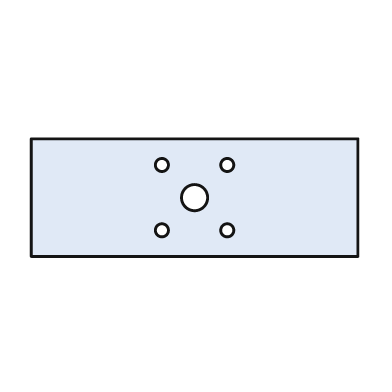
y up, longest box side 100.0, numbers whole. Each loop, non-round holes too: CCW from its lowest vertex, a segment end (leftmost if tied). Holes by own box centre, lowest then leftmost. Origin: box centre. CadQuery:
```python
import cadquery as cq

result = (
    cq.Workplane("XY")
    .moveTo(-50.0, -18.0)
    .lineTo(50.0, -18.0)
    .lineTo(50.0, 18.0)
    .lineTo(-50.0, 18.0)
    .close()
    .moveTo(-10.0, -10.0)
    .circle(2.0)
    .moveTo(10.0, -10.0)
    .circle(2.0)
    .moveTo(0.0, 0.0)
    .circle(4.0)
    .moveTo(-10.0, 10.0)
    .circle(2.0)
    .moveTo(10.0, 10.0)
    .circle(2.0)
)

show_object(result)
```